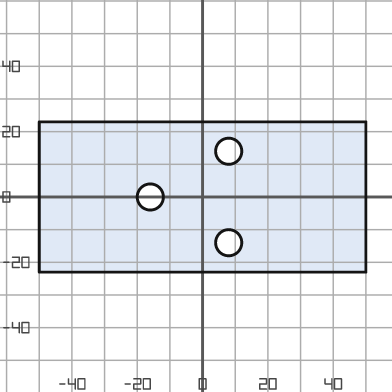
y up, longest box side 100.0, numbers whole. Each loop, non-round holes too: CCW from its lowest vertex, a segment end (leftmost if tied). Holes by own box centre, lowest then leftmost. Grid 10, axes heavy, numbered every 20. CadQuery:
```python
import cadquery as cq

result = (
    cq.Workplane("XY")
    .moveTo(-50.0, -23.0)
    .lineTo(50.0, -23.0)
    .lineTo(50.0, 23.0)
    .lineTo(-50.0, 23.0)
    .close()
    .moveTo(8.0, -14.0)
    .circle(4.0)
    .moveTo(-16.0, 0.0)
    .circle(4.0)
    .moveTo(8.0, 14.0)
    .circle(4.0)
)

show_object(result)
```